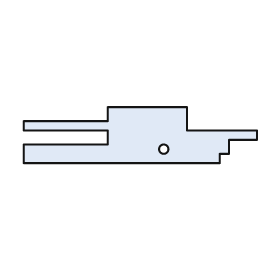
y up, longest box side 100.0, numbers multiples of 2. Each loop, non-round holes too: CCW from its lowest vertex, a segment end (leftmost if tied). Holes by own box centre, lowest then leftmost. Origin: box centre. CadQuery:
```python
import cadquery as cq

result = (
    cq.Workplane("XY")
    .moveTo(-50.0, -12.0)
    .lineTo(34.0, -12.0)
    .lineTo(34.0, -8.0)
    .lineTo(38.0, -8.0)
    .lineTo(38.0, -2.0)
    .lineTo(50.0, -2.0)
    .lineTo(50.0, 2.0)
    .lineTo(20.0, 2.0)
    .lineTo(20.0, 12.0)
    .lineTo(-14.0, 12.0)
    .lineTo(-14.0, 6.0)
    .lineTo(-50.0, 6.0)
    .lineTo(-50.0, 2.0)
    .lineTo(-14.0, 2.0)
    .lineTo(-14.0, -4.0)
    .lineTo(-50.0, -4.0)
    .close()
    .moveTo(10.0, -6.0)
    .circle(2.0)
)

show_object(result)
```